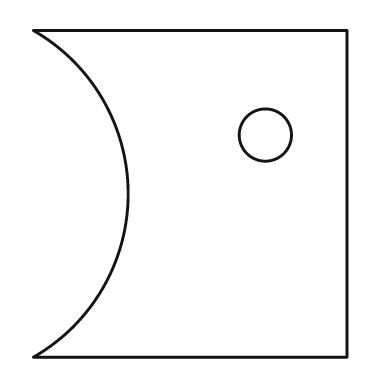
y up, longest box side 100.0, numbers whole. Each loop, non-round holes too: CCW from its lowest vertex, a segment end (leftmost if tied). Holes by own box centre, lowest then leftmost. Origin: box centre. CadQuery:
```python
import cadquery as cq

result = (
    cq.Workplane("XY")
    .moveTo(-48.0, -50.0)
    .lineTo(48.0, -50.0)
    .lineTo(48.0, 50.0)
    .lineTo(-48.0, 50.0)
    .threePointArc((-19.0, 0.0), (-48.0, -50.0))
    .close()
    .moveTo(23.0, 18.0)
    .circle(8.0)
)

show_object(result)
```